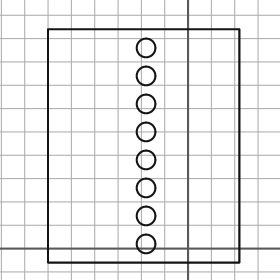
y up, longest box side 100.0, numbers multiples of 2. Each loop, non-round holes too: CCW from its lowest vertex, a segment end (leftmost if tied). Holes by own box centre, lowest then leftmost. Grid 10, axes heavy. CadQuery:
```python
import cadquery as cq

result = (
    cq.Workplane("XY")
    .moveTo(-60.0, -6.0)
    .lineTo(22.0, -6.0)
    .lineTo(22.0, 94.0)
    .lineTo(-60.0, 94.0)
    .close()
    .moveTo(-18.0, 2.0)
    .circle(4.0)
    .moveTo(-18.0, 14.0)
    .circle(4.0)
    .moveTo(-18.0, 26.0)
    .circle(4.0)
    .moveTo(-18.0, 38.0)
    .circle(4.0)
    .moveTo(-18.0, 50.0)
    .circle(4.0)
    .moveTo(-18.0, 62.0)
    .circle(4.0)
    .moveTo(-18.0, 74.0)
    .circle(4.0)
    .moveTo(-18.0, 86.0)
    .circle(4.0)
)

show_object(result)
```